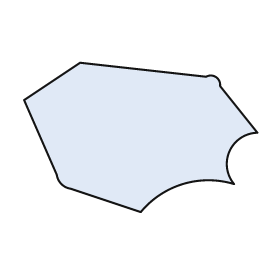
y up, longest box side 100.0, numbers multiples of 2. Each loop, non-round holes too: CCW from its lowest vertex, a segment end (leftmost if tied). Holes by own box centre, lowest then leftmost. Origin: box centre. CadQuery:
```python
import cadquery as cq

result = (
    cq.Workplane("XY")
    .moveTo(0.0, -32.0)
    .threePointArc((18.0, -20.0), (40.0, -20.0))
    .threePointArc((38.0, -6.0), (50.0, 2.0))
    .lineTo(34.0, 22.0)
    .threePointArc((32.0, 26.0), (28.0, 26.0))
    .lineTo(-26.0, 32.0)
    .lineTo(-50.0, 16.0)
    .lineTo(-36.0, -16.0)
    .threePointArc((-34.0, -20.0), (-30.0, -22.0))
    .close()
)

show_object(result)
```